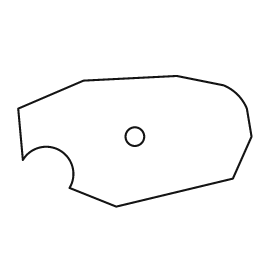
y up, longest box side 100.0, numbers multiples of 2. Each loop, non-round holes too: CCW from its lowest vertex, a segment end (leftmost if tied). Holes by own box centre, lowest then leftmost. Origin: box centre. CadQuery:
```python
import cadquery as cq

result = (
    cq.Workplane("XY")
    .moveTo(-8.0, -28.0)
    .lineTo(42.0, -16.0)
    .lineTo(50.0, 2.0)
    .lineTo(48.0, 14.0)
    .threePointArc((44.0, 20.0), (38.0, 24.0))
    .lineTo(18.0, 28.0)
    .lineTo(-22.0, 26.0)
    .lineTo(-50.0, 14.0)
    .lineTo(-48.0, -8.0)
    .threePointArc((-32.0, -4.0), (-28.0, -20.0))
    .close()
    .moveTo(0.0, 2.0)
    .circle(4.0)
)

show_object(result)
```